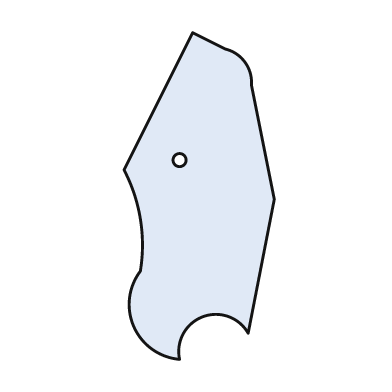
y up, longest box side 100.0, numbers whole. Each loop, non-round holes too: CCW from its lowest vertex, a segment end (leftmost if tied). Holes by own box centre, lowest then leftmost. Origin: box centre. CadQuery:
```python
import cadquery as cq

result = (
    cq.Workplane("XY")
    .moveTo(-6.0, -50.0)
    .threePointArc((1.0, -37.0), (15.0, -42.0))
    .lineTo(23.0, -1.0)
    .lineTo(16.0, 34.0)
    .threePointArc((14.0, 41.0), (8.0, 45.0))
    .lineTo(-2.0, 50.0)
    .lineTo(-23.0, 8.0)
    .threePointArc((-18.0, -7.0), (-18.0, -23.0))
    .threePointArc((-20.0, -40.0), (-6.0, -50.0))
    .close()
    .moveTo(-6.0, 11.0)
    .circle(2.0)
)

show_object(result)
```